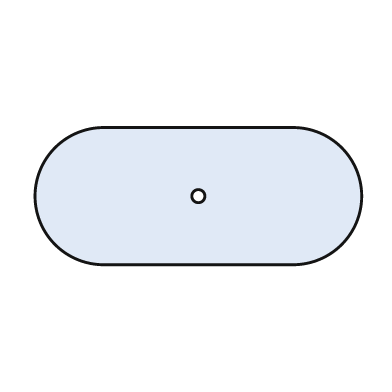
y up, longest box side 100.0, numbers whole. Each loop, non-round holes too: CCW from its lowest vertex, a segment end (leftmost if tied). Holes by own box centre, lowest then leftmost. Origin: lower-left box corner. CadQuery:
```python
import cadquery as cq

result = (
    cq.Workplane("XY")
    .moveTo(21.0, 0.0)
    .lineTo(79.0, 0.0)
    .threePointArc((100.0, 21.0), (79.0, 42.0))
    .lineTo(21.0, 42.0)
    .threePointArc((0.0, 21.0), (21.0, 0.0))
    .close()
    .moveTo(50.0, 21.0)
    .circle(2.0)
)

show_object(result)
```